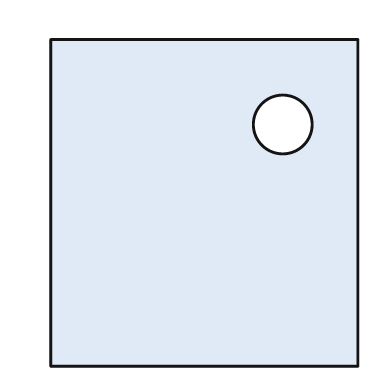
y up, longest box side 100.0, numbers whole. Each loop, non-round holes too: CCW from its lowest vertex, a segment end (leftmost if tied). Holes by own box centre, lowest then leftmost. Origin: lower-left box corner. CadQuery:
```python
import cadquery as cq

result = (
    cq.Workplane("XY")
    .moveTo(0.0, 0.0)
    .lineTo(94.0, 0.0)
    .lineTo(94.0, 100.0)
    .lineTo(0.0, 100.0)
    .close()
    .moveTo(71.0, 74.0)
    .circle(9.0)
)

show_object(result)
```